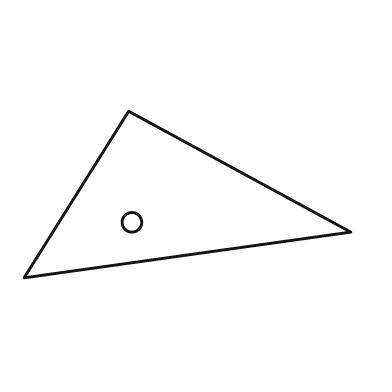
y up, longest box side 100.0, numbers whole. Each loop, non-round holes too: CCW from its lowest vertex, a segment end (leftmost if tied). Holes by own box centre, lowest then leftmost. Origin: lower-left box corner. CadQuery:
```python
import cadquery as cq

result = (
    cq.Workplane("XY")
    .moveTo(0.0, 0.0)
    .lineTo(100.0, 14.0)
    .lineTo(32.0, 51.0)
    .close()
    .moveTo(33.0, 17.0)
    .circle(3.0)
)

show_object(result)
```